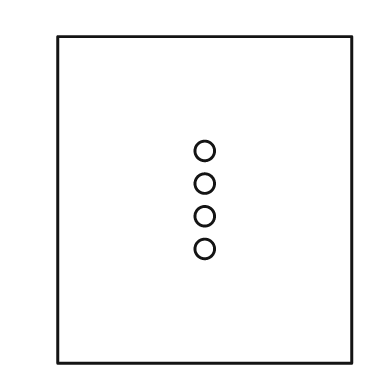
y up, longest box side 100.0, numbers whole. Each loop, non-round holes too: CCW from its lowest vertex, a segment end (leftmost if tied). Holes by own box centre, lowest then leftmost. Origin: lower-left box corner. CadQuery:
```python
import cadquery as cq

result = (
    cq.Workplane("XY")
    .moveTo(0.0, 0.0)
    .lineTo(90.0, 0.0)
    .lineTo(90.0, 100.0)
    .lineTo(0.0, 100.0)
    .close()
    .moveTo(45.0, 35.0)
    .circle(3.0)
    .moveTo(45.0, 45.0)
    .circle(3.0)
    .moveTo(45.0, 55.0)
    .circle(3.0)
    .moveTo(45.0, 65.0)
    .circle(3.0)
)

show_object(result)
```